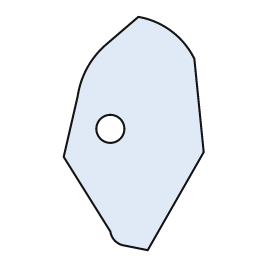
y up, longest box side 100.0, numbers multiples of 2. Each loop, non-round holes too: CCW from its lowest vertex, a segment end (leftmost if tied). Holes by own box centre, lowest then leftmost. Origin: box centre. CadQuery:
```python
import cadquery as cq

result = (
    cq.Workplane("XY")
    .moveTo(6.0, -50.0)
    .lineTo(30.0, -8.0)
    .lineTo(26.0, 32.0)
    .threePointArc((16.0, 44.0), (2.0, 50.0))
    .lineTo(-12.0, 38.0)
    .threePointArc((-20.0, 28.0), (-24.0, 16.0))
    .lineTo(-30.0, -10.0)
    .lineTo(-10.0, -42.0)
    .threePointArc((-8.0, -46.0), (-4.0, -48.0))
    .close()
    .moveTo(-10.0, 2.0)
    .circle(6.0)
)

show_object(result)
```